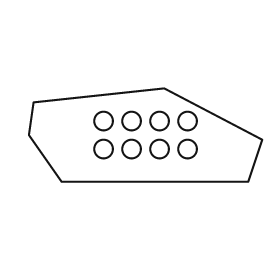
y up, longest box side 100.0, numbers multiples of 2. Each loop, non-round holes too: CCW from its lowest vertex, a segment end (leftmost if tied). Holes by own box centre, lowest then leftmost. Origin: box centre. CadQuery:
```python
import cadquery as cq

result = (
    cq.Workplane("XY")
    .moveTo(-36.0, -20.0)
    .lineTo(44.0, -20.0)
    .lineTo(50.0, -2.0)
    .lineTo(8.0, 20.0)
    .lineTo(-48.0, 14.0)
    .lineTo(-50.0, 0.0)
    .close()
    .moveTo(-18.0, -6.0)
    .circle(4.0)
    .moveTo(-6.0, -6.0)
    .circle(4.0)
    .moveTo(6.0, -6.0)
    .circle(4.0)
    .moveTo(18.0, -6.0)
    .circle(4.0)
    .moveTo(-18.0, 6.0)
    .circle(4.0)
    .moveTo(-6.0, 6.0)
    .circle(4.0)
    .moveTo(6.0, 6.0)
    .circle(4.0)
    .moveTo(18.0, 6.0)
    .circle(4.0)
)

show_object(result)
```